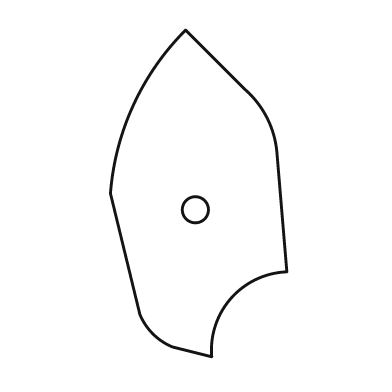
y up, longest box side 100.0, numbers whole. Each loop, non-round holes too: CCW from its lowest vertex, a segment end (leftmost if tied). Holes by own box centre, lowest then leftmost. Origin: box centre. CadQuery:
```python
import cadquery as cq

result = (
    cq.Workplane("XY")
    .moveTo(4.0, -50.0)
    .threePointArc((10.0, -32.0), (27.0, -24.0))
    .lineTo(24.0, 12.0)
    .threePointArc((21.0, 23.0), (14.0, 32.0))
    .lineTo(-4.0, 50.0)
    .threePointArc((-20.0, 27.0), (-27.0, 0.0))
    .lineTo(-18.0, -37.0)
    .threePointArc((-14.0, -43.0), (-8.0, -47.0))
    .close()
    .moveTo(-1.0, -5.0)
    .circle(4.0)
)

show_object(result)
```